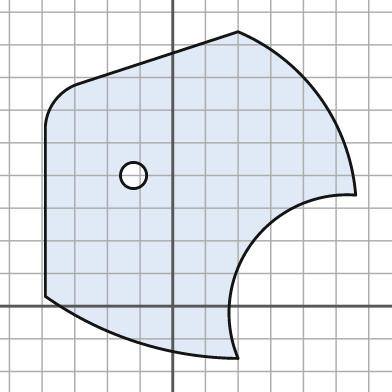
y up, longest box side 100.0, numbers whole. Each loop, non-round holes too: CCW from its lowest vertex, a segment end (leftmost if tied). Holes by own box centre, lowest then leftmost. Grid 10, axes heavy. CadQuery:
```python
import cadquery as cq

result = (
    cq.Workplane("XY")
    .moveTo(20.0, -16.0)
    .threePointArc((24.0, 19.0), (56.0, 34.0))
    .threePointArc((45.0, 64.0), (20.0, 84.0))
    .lineTo(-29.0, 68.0)
    .threePointArc((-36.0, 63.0), (-39.0, 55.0))
    .lineTo(-39.0, 3.0)
    .threePointArc((-11.0, -11.0), (20.0, -16.0))
    .close()
    .moveTo(-12.0, 40.0)
    .circle(4.0)
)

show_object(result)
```